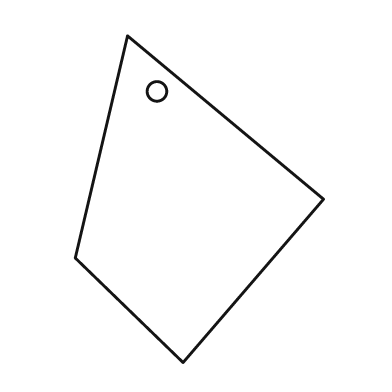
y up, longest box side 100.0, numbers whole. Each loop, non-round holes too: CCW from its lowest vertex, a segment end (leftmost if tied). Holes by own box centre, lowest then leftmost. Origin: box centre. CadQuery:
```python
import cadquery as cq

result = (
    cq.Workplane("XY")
    .moveTo(-5.0, -50.0)
    .lineTo(38.0, 0.0)
    .lineTo(-22.0, 50.0)
    .lineTo(-38.0, -18.0)
    .close()
    .moveTo(-13.0, 33.0)
    .circle(3.0)
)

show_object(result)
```